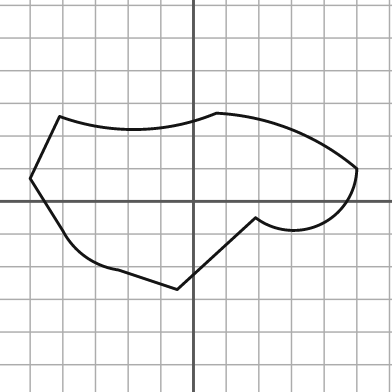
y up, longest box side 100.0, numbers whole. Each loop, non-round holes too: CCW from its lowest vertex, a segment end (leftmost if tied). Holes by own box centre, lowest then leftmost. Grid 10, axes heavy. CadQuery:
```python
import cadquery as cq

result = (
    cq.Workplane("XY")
    .moveTo(-5.0, -27.0)
    .lineTo(19.0, -5.0)
    .threePointArc((39.0, -7.0), (50.0, 10.0))
    .threePointArc((30.0, 22.0), (7.0, 27.0))
    .threePointArc((-17.0, 22.0), (-41.0, 26.0))
    .lineTo(-50.0, 7.0)
    .lineTo(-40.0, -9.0)
    .threePointArc((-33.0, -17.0), (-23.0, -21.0))
    .close()
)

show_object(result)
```